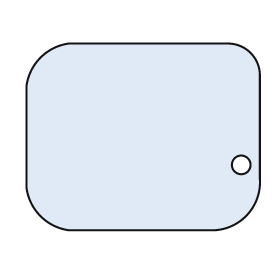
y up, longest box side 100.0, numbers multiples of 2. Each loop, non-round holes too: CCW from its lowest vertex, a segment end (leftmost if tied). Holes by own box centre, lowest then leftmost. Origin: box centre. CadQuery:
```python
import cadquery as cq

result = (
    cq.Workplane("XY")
    .moveTo(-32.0, -40.0)
    .lineTo(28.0, -40.0)
    .threePointArc((44.0, -34.0), (50.0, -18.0))
    .lineTo(50.0, 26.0)
    .threePointArc((46.0, 36.0), (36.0, 40.0))
    .lineTo(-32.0, 40.0)
    .threePointArc((-44.0, 34.0), (-50.0, 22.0))
    .lineTo(-50.0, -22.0)
    .threePointArc((-44.0, -34.0), (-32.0, -40.0))
    .close()
    .moveTo(42.0, -12.0)
    .circle(4.0)
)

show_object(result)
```